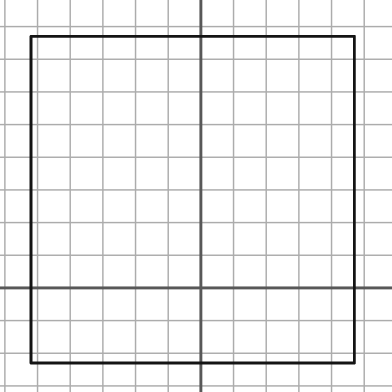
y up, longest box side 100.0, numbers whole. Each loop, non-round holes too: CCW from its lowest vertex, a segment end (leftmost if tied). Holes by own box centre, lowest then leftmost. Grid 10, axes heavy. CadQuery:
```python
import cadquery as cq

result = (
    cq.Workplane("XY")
    .moveTo(-52.0, -23.0)
    .lineTo(47.0, -23.0)
    .lineTo(47.0, 77.0)
    .lineTo(-52.0, 77.0)
    .close()
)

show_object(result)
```